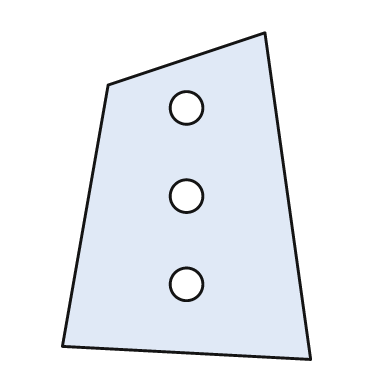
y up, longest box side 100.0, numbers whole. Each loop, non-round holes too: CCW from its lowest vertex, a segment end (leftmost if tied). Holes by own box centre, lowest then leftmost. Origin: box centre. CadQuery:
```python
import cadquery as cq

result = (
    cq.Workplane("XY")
    .moveTo(38.0, -50.0)
    .lineTo(24.0, 50.0)
    .lineTo(-24.0, 34.0)
    .lineTo(-38.0, -46.0)
    .close()
    .moveTo(0.0, -27.0)
    .circle(5.0)
    .moveTo(0.0, 0.0)
    .circle(5.0)
    .moveTo(0.0, 27.0)
    .circle(5.0)
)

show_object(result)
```